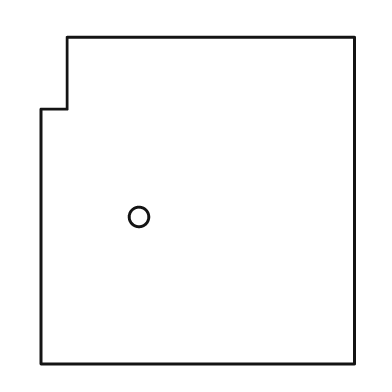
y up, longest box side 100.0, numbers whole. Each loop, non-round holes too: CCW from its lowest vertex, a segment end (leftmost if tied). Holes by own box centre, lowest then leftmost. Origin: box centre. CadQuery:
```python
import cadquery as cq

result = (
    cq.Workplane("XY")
    .moveTo(-48.0, -50.0)
    .lineTo(48.0, -50.0)
    .lineTo(48.0, 50.0)
    .lineTo(-40.0, 50.0)
    .lineTo(-40.0, 28.0)
    .lineTo(-48.0, 28.0)
    .close()
    .moveTo(-18.0, -5.0)
    .circle(3.0)
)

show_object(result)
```